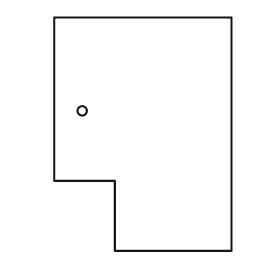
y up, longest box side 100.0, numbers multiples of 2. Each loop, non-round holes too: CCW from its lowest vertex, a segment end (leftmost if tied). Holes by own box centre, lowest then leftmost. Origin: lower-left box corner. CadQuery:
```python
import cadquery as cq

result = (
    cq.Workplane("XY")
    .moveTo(26.0, 0.0)
    .lineTo(76.0, 0.0)
    .lineTo(76.0, 100.0)
    .lineTo(0.0, 100.0)
    .lineTo(0.0, 30.0)
    .lineTo(26.0, 30.0)
    .close()
    .moveTo(12.0, 60.0)
    .circle(2.0)
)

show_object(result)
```